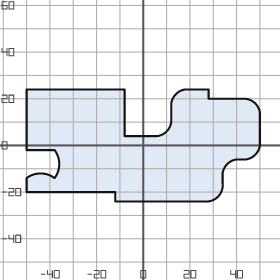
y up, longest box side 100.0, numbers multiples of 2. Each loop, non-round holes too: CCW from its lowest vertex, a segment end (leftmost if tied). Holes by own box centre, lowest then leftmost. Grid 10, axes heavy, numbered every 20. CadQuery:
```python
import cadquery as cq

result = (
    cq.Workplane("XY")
    .moveTo(-12.0, -24.0)
    .lineTo(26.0, -24.0)
    .threePointArc((32.0, -22.0), (34.0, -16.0))
    .lineTo(34.0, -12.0)
    .threePointArc((36.0, -8.0), (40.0, -6.0))
    .lineTo(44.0, -6.0)
    .threePointArc((48.0, -4.0), (50.0, 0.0))
    .lineTo(50.0, 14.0)
    .threePointArc((48.0, 18.0), (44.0, 20.0))
    .lineTo(28.0, 20.0)
    .lineTo(28.0, 24.0)
    .lineTo(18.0, 24.0)
    .threePointArc((14.0, 22.0), (12.0, 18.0))
    .lineTo(12.0, 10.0)
    .threePointArc((10.0, 6.0), (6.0, 4.0))
    .lineTo(-8.0, 4.0)
    .lineTo(-8.0, 24.0)
    .lineTo(-50.0, 24.0)
    .lineTo(-50.0, -2.0)
    .lineTo(-38.0, -2.0)
    .threePointArc((-36.0, -8.0), (-38.0, -14.0))
    .threePointArc((-44.0, -12.0), (-50.0, -14.0))
    .lineTo(-50.0, -20.0)
    .lineTo(-12.0, -20.0)
    .close()
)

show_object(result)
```